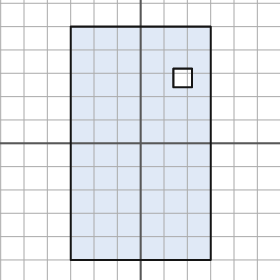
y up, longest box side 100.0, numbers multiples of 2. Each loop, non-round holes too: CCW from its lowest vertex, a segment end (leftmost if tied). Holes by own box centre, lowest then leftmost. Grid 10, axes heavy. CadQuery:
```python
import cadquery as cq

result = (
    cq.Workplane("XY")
    .moveTo(-30.0, -50.0)
    .lineTo(30.0, -50.0)
    .lineTo(30.0, 50.0)
    .lineTo(-30.0, 50.0)
    .close()
    .moveTo(14.0, 24.0)
    .lineTo(22.0, 24.0)
    .lineTo(22.0, 32.0)
    .lineTo(14.0, 32.0)
    .close()
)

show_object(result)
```